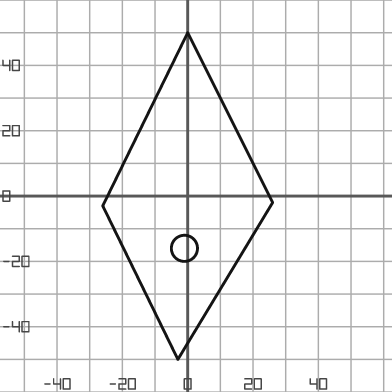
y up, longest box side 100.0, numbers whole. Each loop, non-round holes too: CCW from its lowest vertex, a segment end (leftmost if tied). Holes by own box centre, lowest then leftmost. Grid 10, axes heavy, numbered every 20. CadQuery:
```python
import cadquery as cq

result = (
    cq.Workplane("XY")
    .moveTo(-3.0, -50.0)
    .lineTo(26.0, -2.0)
    .lineTo(0.0, 50.0)
    .lineTo(-26.0, -3.0)
    .close()
    .moveTo(-1.0, -16.0)
    .circle(4.0)
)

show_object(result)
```